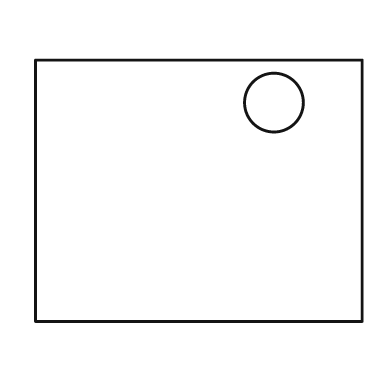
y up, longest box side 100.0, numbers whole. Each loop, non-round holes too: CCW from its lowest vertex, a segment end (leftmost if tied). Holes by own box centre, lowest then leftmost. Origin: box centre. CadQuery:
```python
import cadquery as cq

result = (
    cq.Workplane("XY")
    .moveTo(-50.0, -40.0)
    .lineTo(50.0, -40.0)
    .lineTo(50.0, 40.0)
    .lineTo(-50.0, 40.0)
    .close()
    .moveTo(23.0, 27.0)
    .circle(9.0)
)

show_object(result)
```